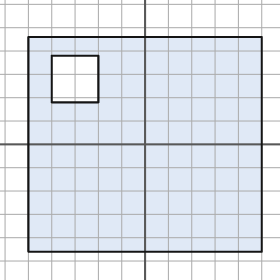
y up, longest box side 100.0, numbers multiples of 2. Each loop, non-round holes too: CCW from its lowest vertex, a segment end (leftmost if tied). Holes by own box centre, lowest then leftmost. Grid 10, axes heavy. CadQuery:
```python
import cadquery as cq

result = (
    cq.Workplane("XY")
    .moveTo(-50.0, -46.0)
    .lineTo(50.0, -46.0)
    .lineTo(50.0, 46.0)
    .lineTo(-50.0, 46.0)
    .close()
    .moveTo(-40.0, 18.0)
    .lineTo(-20.0, 18.0)
    .lineTo(-20.0, 38.0)
    .lineTo(-40.0, 38.0)
    .close()
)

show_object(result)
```